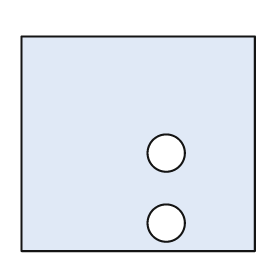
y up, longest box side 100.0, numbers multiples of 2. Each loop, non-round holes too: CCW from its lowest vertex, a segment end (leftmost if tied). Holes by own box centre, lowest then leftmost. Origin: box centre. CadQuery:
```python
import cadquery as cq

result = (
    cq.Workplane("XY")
    .moveTo(-50.0, -46.0)
    .lineTo(50.0, -46.0)
    .lineTo(50.0, 46.0)
    .lineTo(-50.0, 46.0)
    .close()
    .moveTo(12.0, -34.0)
    .circle(8.0)
    .moveTo(12.0, -4.0)
    .circle(8.0)
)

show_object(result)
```